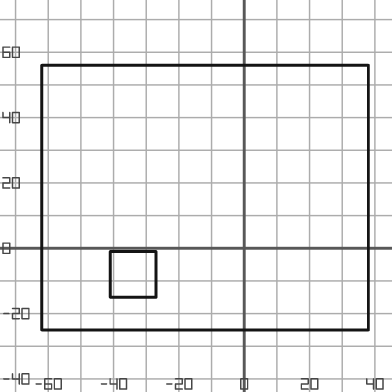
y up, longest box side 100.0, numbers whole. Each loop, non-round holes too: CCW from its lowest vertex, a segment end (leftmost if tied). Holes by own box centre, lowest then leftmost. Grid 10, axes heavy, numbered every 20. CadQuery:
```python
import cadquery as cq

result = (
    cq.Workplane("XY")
    .moveTo(-62.0, -25.0)
    .lineTo(38.0, -25.0)
    .lineTo(38.0, 56.0)
    .lineTo(-62.0, 56.0)
    .close()
    .moveTo(-41.0, -15.0)
    .lineTo(-27.0, -15.0)
    .lineTo(-27.0, -1.0)
    .lineTo(-41.0, -1.0)
    .close()
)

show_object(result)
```